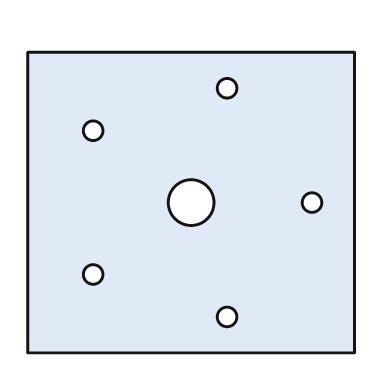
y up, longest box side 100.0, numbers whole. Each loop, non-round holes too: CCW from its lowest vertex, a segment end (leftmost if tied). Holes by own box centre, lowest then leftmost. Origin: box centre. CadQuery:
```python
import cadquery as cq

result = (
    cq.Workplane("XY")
    .moveTo(-50.0, -46.0)
    .lineTo(50.0, -46.0)
    .lineTo(50.0, 46.0)
    .lineTo(-50.0, 46.0)
    .close()
    .moveTo(11.0, -35.0)
    .circle(3.0)
    .moveTo(-30.0, -22.0)
    .circle(3.0)
    .moveTo(0.0, 0.0)
    .circle(7.0)
    .moveTo(37.0, 0.0)
    .circle(3.0)
    .moveTo(-30.0, 22.0)
    .circle(3.0)
    .moveTo(11.0, 35.0)
    .circle(3.0)
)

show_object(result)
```